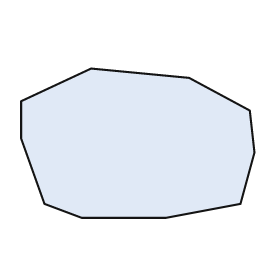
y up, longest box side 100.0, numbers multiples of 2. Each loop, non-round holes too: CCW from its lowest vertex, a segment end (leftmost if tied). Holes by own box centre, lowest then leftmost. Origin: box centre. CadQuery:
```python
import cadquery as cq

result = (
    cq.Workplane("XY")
    .moveTo(-24.0, -32.0)
    .lineTo(12.0, -32.0)
    .lineTo(44.0, -26.0)
    .lineTo(50.0, -4.0)
    .lineTo(48.0, 14.0)
    .lineTo(22.0, 28.0)
    .lineTo(-20.0, 32.0)
    .lineTo(-50.0, 18.0)
    .lineTo(-50.0, 2.0)
    .lineTo(-40.0, -26.0)
    .close()
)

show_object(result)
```